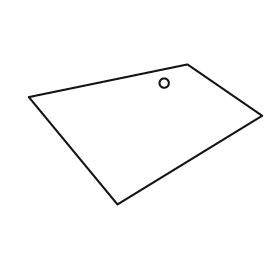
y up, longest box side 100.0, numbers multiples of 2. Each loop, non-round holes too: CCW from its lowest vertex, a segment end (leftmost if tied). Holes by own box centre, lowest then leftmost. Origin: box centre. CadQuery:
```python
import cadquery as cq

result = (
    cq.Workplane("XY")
    .moveTo(-12.0, -30.0)
    .lineTo(50.0, 8.0)
    .lineTo(18.0, 30.0)
    .lineTo(-50.0, 16.0)
    .close()
    .moveTo(8.0, 22.0)
    .circle(2.0)
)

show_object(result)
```